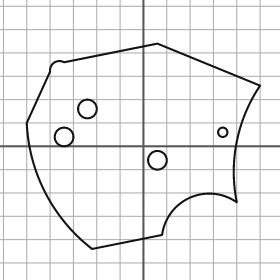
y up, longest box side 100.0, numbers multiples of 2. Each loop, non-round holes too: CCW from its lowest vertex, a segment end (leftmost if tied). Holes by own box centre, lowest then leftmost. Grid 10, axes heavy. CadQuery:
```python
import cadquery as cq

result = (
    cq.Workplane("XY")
    .moveTo(-22.0, -44.0)
    .lineTo(8.0, -38.0)
    .threePointArc((20.0, -22.0), (40.0, -24.0))
    .threePointArc((40.0, 2.0), (50.0, 26.0))
    .lineTo(6.0, 44.0)
    .lineTo(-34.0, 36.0)
    .threePointArc((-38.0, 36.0), (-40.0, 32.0))
    .lineTo(-50.0, 10.0)
    .threePointArc((-42.0, -20.0), (-22.0, -44.0))
    .close()
    .moveTo(6.0, -6.0)
    .circle(4.0)
    .moveTo(-34.0, 4.0)
    .circle(4.0)
    .moveTo(34.0, 6.0)
    .circle(2.0)
    .moveTo(-24.0, 16.0)
    .circle(4.0)
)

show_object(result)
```